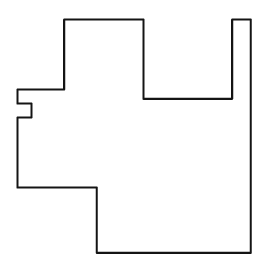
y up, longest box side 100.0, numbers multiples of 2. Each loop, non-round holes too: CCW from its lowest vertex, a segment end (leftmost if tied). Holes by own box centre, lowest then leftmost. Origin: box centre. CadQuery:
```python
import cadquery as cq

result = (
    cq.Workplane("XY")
    .moveTo(-16.0, -50.0)
    .lineTo(50.0, -50.0)
    .lineTo(50.0, 50.0)
    .lineTo(42.0, 50.0)
    .lineTo(42.0, 16.0)
    .lineTo(4.0, 16.0)
    .lineTo(4.0, 50.0)
    .lineTo(-30.0, 50.0)
    .lineTo(-30.0, 20.0)
    .lineTo(-50.0, 20.0)
    .lineTo(-50.0, 14.0)
    .lineTo(-44.0, 14.0)
    .lineTo(-44.0, 8.0)
    .lineTo(-50.0, 8.0)
    .lineTo(-50.0, -22.0)
    .lineTo(-16.0, -22.0)
    .close()
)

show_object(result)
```